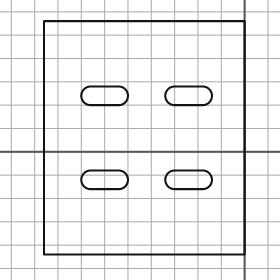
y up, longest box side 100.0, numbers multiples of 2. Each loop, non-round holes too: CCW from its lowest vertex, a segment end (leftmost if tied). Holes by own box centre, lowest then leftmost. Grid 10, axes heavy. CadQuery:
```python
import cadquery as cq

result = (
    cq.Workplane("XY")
    .moveTo(-86.0, -44.0)
    .lineTo(0.0, -44.0)
    .lineTo(0.0, 56.0)
    .lineTo(-86.0, 56.0)
    .close()
    .moveTo(-66.0, -16.0)
    .lineTo(-54.0, -16.0)
    .threePointArc((-50.0, -12.0), (-54.0, -8.0))
    .lineTo(-66.0, -8.0)
    .threePointArc((-70.0, -12.0), (-66.0, -16.0))
    .close()
    .moveTo(-30.0, -16.0)
    .lineTo(-18.0, -16.0)
    .threePointArc((-14.0, -12.0), (-18.0, -8.0))
    .lineTo(-30.0, -8.0)
    .threePointArc((-34.0, -12.0), (-30.0, -16.0))
    .close()
    .moveTo(-66.0, 20.0)
    .lineTo(-54.0, 20.0)
    .threePointArc((-50.0, 24.0), (-54.0, 28.0))
    .lineTo(-66.0, 28.0)
    .threePointArc((-70.0, 24.0), (-66.0, 20.0))
    .close()
    .moveTo(-30.0, 20.0)
    .lineTo(-18.0, 20.0)
    .threePointArc((-14.0, 24.0), (-18.0, 28.0))
    .lineTo(-30.0, 28.0)
    .threePointArc((-34.0, 24.0), (-30.0, 20.0))
    .close()
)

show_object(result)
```